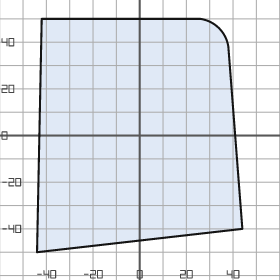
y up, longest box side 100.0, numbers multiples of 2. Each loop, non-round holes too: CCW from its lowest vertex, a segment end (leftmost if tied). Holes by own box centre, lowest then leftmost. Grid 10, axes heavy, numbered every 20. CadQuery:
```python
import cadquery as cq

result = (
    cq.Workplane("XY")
    .moveTo(-44.0, -50.0)
    .lineTo(44.0, -40.0)
    .lineTo(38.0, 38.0)
    .threePointArc((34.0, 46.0), (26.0, 50.0))
    .lineTo(-42.0, 50.0)
    .close()
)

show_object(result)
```